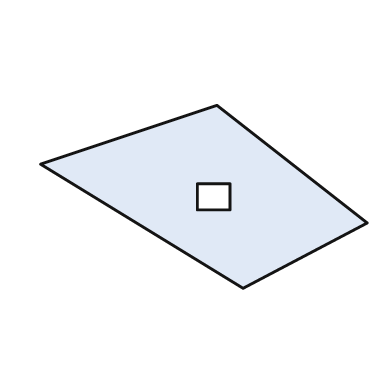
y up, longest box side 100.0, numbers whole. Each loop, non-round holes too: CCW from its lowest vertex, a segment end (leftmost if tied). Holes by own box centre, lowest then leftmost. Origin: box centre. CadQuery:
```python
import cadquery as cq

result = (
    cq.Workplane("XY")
    .moveTo(12.0, -28.0)
    .lineTo(50.0, -8.0)
    .lineTo(4.0, 28.0)
    .lineTo(-50.0, 10.0)
    .close()
    .moveTo(-2.0, -4.0)
    .lineTo(8.0, -4.0)
    .lineTo(8.0, 4.0)
    .lineTo(-2.0, 4.0)
    .close()
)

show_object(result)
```